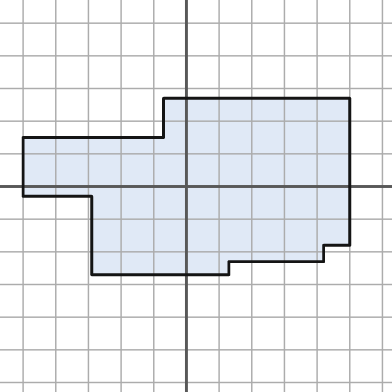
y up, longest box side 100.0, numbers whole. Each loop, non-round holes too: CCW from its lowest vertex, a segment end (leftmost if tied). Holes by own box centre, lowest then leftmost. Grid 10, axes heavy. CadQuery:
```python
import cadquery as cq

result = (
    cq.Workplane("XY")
    .moveTo(-29.0, -27.0)
    .lineTo(13.0, -27.0)
    .lineTo(13.0, -23.0)
    .lineTo(42.0, -23.0)
    .lineTo(42.0, -18.0)
    .lineTo(50.0, -18.0)
    .lineTo(50.0, 27.0)
    .lineTo(-7.0, 27.0)
    .lineTo(-7.0, 15.0)
    .lineTo(-50.0, 15.0)
    .lineTo(-50.0, -3.0)
    .lineTo(-29.0, -3.0)
    .close()
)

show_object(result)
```